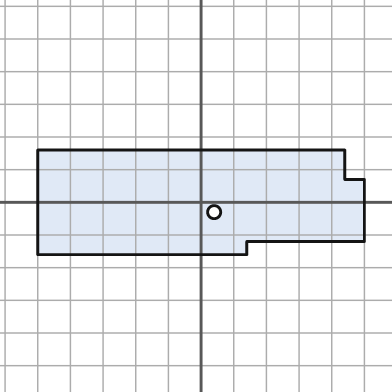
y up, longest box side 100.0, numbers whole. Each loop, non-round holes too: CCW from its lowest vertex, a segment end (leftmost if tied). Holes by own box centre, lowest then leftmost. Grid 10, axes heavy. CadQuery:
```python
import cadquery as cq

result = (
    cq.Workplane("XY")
    .moveTo(-50.0, -16.0)
    .lineTo(14.0, -16.0)
    .lineTo(14.0, -12.0)
    .lineTo(50.0, -12.0)
    .lineTo(50.0, 7.0)
    .lineTo(44.0, 7.0)
    .lineTo(44.0, 16.0)
    .lineTo(-50.0, 16.0)
    .close()
    .moveTo(4.0, -3.0)
    .circle(2.0)
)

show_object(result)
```